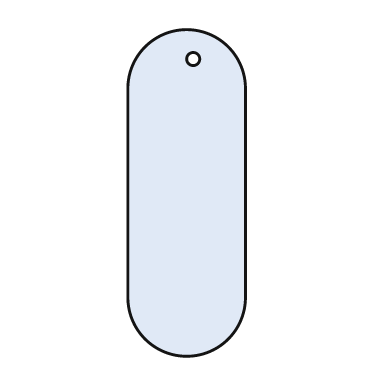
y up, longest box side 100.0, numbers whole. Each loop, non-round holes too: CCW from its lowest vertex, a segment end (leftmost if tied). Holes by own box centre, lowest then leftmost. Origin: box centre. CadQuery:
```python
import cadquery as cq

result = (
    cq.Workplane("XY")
    .moveTo(-18.0, -32.0)
    .threePointArc((0.0, -50.0), (18.0, -32.0))
    .lineTo(18.0, 32.0)
    .threePointArc((0.0, 50.0), (-18.0, 32.0))
    .close()
    .moveTo(2.0, 41.0)
    .circle(2.0)
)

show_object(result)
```